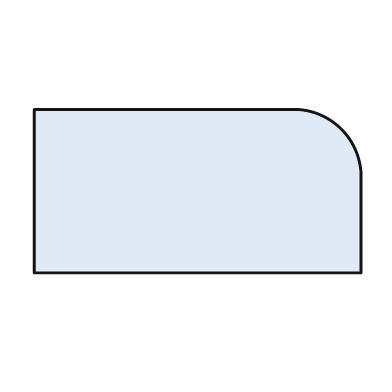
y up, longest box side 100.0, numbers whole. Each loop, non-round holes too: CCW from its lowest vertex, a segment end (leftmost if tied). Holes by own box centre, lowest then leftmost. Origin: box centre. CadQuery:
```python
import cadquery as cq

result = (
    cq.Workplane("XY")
    .moveTo(-50.0, -25.0)
    .lineTo(50.0, -25.0)
    .lineTo(50.0, 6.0)
    .threePointArc((44.0, 19.0), (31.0, 25.0))
    .lineTo(-50.0, 25.0)
    .close()
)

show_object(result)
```